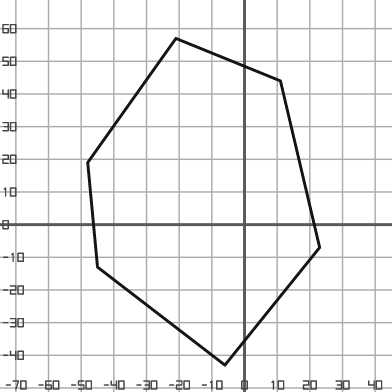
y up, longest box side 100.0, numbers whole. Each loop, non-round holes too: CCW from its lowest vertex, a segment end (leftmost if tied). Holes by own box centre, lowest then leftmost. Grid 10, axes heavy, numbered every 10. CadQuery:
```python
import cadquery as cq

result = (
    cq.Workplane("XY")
    .moveTo(-6.0, -43.0)
    .lineTo(23.0, -7.0)
    .lineTo(11.0, 44.0)
    .lineTo(-21.0, 57.0)
    .lineTo(-48.0, 19.0)
    .lineTo(-45.0, -13.0)
    .close()
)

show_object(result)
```